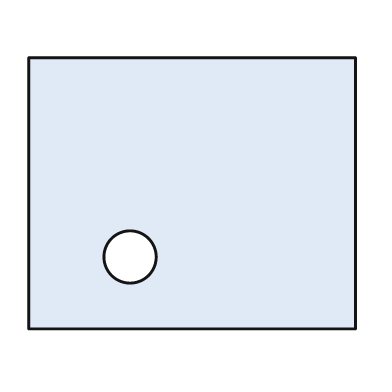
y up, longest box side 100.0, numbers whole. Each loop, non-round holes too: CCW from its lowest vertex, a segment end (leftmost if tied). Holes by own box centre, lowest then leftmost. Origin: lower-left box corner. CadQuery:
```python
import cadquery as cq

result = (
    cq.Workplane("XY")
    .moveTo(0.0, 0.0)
    .lineTo(100.0, 0.0)
    .lineTo(100.0, 83.0)
    .lineTo(0.0, 83.0)
    .close()
    .moveTo(31.0, 22.0)
    .circle(8.0)
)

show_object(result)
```